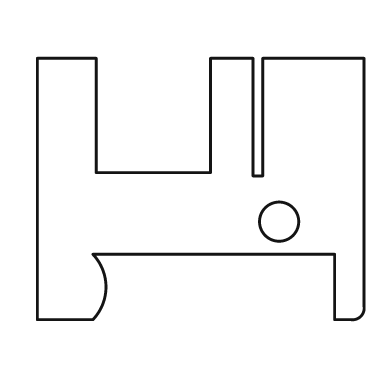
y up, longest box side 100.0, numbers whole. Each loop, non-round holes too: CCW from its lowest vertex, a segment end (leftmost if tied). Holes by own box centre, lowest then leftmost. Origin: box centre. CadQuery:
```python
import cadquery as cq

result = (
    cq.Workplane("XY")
    .moveTo(-50.0, -40.0)
    .lineTo(-33.0, -40.0)
    .threePointArc((-29.0, -30.0), (-33.0, -20.0))
    .lineTo(41.0, -20.0)
    .lineTo(41.0, -40.0)
    .lineTo(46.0, -40.0)
    .threePointArc((49.0, -39.0), (50.0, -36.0))
    .lineTo(50.0, 40.0)
    .lineTo(19.0, 40.0)
    .lineTo(19.0, 4.0)
    .lineTo(16.0, 4.0)
    .lineTo(16.0, 40.0)
    .lineTo(3.0, 40.0)
    .lineTo(3.0, 5.0)
    .lineTo(-32.0, 5.0)
    .lineTo(-32.0, 40.0)
    .lineTo(-50.0, 40.0)
    .close()
    .moveTo(24.0, -10.0)
    .circle(6.0)
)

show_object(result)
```